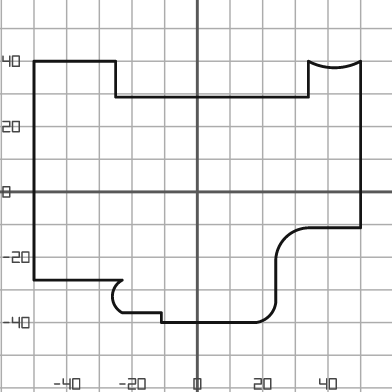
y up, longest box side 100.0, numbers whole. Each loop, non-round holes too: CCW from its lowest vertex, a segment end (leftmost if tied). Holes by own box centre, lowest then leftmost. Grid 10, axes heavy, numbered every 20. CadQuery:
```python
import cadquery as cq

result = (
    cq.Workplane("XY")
    .moveTo(-11.0, -40.0)
    .lineTo(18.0, -40.0)
    .threePointArc((22.0, -38.0), (24.0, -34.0))
    .lineTo(24.0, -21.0)
    .threePointArc((27.0, -14.0), (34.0, -11.0))
    .lineTo(50.0, -11.0)
    .lineTo(50.0, 40.0)
    .threePointArc((42.0, 38.0), (34.0, 40.0))
    .lineTo(34.0, 29.0)
    .lineTo(-25.0, 29.0)
    .lineTo(-25.0, 40.0)
    .lineTo(-50.0, 40.0)
    .lineTo(-50.0, -27.0)
    .lineTo(-23.0, -27.0)
    .threePointArc((-26.0, -32.0), (-23.0, -37.0))
    .lineTo(-11.0, -37.0)
    .close()
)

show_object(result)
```